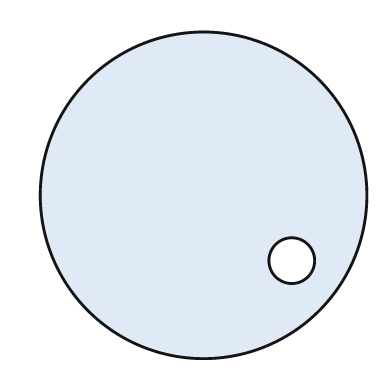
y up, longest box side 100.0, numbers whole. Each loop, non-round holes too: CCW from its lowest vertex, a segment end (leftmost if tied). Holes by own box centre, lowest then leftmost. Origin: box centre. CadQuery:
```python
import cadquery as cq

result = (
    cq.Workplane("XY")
    .moveTo(0.0, 0.0)
    .circle(50.0)
    .moveTo(27.0, -20.0)
    .circle(7.0)
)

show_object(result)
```